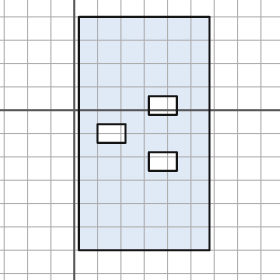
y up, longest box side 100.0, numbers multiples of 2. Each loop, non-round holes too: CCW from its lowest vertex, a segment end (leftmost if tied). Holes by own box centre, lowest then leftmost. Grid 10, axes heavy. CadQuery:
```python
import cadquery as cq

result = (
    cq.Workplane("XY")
    .moveTo(2.0, -60.0)
    .lineTo(58.0, -60.0)
    .lineTo(58.0, 40.0)
    .lineTo(2.0, 40.0)
    .close()
    .moveTo(32.0, -26.0)
    .lineTo(44.0, -26.0)
    .lineTo(44.0, -18.0)
    .lineTo(32.0, -18.0)
    .close()
    .moveTo(10.0, -14.0)
    .lineTo(22.0, -14.0)
    .lineTo(22.0, -6.0)
    .lineTo(10.0, -6.0)
    .close()
    .moveTo(32.0, -2.0)
    .lineTo(44.0, -2.0)
    .lineTo(44.0, 6.0)
    .lineTo(32.0, 6.0)
    .close()
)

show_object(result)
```